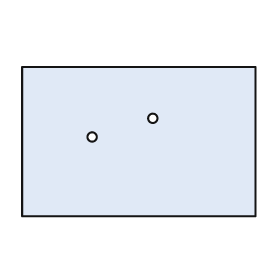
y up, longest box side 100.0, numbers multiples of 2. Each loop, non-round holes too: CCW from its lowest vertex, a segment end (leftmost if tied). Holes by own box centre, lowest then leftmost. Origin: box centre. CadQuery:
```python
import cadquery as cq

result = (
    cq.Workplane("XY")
    .moveTo(-50.0, -32.0)
    .lineTo(50.0, -32.0)
    .lineTo(50.0, 32.0)
    .lineTo(-50.0, 32.0)
    .close()
    .moveTo(-20.0, 2.0)
    .circle(2.0)
    .moveTo(6.0, 10.0)
    .circle(2.0)
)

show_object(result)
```